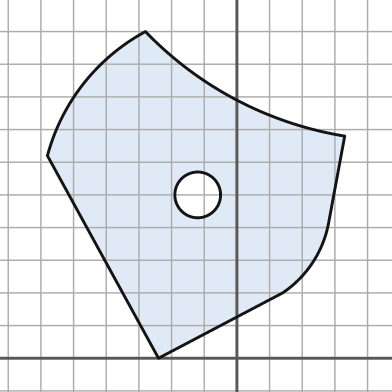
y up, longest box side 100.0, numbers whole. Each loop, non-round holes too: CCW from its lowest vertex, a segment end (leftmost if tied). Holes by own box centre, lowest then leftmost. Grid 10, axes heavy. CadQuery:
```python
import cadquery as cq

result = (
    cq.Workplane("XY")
    .moveTo(-24.0, 0.0)
    .lineTo(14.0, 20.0)
    .threePointArc((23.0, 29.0), (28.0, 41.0))
    .lineTo(33.0, 68.0)
    .threePointArc((0.0, 79.0), (-28.0, 100.0))
    .threePointArc((-47.0, 84.0), (-58.0, 62.0))
    .close()
    .moveTo(-12.0, 50.0)
    .circle(7.0)
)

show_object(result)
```